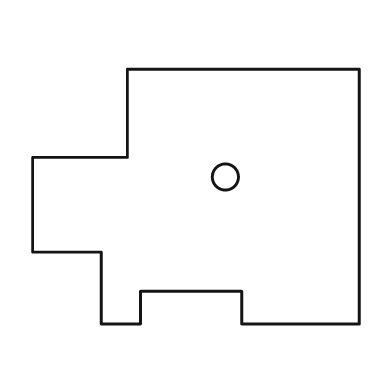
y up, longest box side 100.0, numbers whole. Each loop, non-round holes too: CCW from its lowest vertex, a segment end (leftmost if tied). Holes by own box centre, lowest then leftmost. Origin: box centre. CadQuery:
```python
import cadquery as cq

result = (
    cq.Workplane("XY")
    .moveTo(-29.0, -39.0)
    .lineTo(-17.0, -39.0)
    .lineTo(-17.0, -29.0)
    .lineTo(14.0, -29.0)
    .lineTo(14.0, -39.0)
    .lineTo(50.0, -39.0)
    .lineTo(50.0, 39.0)
    .lineTo(-21.0, 39.0)
    .lineTo(-21.0, 12.0)
    .lineTo(-50.0, 12.0)
    .lineTo(-50.0, -17.0)
    .lineTo(-29.0, -17.0)
    .close()
    .moveTo(9.0, 6.0)
    .circle(4.0)
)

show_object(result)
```